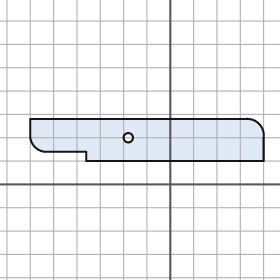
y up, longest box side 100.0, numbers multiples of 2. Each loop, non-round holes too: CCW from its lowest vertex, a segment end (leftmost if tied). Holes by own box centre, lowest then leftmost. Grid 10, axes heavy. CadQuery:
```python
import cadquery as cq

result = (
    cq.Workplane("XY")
    .moveTo(-36.0, 10.0)
    .lineTo(40.0, 10.0)
    .lineTo(40.0, 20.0)
    .threePointArc((38.0, 26.0), (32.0, 28.0))
    .lineTo(-60.0, 28.0)
    .lineTo(-60.0, 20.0)
    .threePointArc((-58.0, 16.0), (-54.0, 14.0))
    .lineTo(-36.0, 14.0)
    .close()
    .moveTo(-18.0, 20.0)
    .circle(2.0)
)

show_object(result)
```